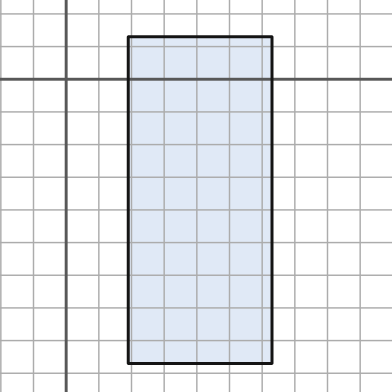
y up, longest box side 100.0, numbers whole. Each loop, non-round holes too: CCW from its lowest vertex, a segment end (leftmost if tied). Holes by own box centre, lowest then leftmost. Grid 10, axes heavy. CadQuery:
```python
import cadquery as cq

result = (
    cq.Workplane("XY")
    .moveTo(19.0, -87.0)
    .lineTo(63.0, -87.0)
    .lineTo(63.0, 13.0)
    .lineTo(19.0, 13.0)
    .close()
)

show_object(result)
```